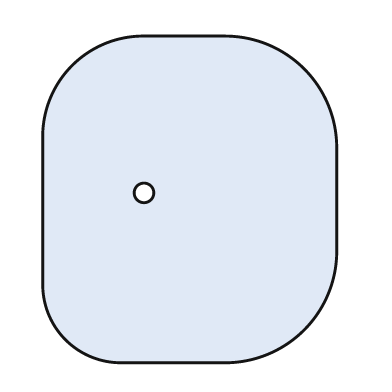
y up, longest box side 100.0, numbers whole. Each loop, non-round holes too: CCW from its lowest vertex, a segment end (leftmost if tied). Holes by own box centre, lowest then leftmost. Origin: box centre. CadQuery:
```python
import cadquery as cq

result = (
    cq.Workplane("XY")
    .moveTo(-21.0, -50.0)
    .lineTo(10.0, -50.0)
    .threePointArc((35.0, -40.0), (45.0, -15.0))
    .lineTo(45.0, 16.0)
    .threePointArc((35.0, 40.0), (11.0, 50.0))
    .lineTo(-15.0, 50.0)
    .threePointArc((-36.0, 41.0), (-45.0, 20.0))
    .lineTo(-45.0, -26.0)
    .threePointArc((-38.0, -43.0), (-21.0, -50.0))
    .close()
    .moveTo(-14.0, 2.0)
    .circle(3.0)
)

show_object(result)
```